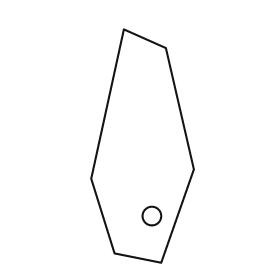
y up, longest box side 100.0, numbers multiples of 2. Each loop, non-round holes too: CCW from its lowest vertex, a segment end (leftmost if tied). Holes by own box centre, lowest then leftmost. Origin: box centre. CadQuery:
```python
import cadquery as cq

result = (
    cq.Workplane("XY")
    .moveTo(8.0, -50.0)
    .lineTo(22.0, -10.0)
    .lineTo(10.0, 42.0)
    .lineTo(-8.0, 50.0)
    .lineTo(-22.0, -14.0)
    .lineTo(-12.0, -46.0)
    .close()
    .moveTo(4.0, -30.0)
    .circle(4.0)
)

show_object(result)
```